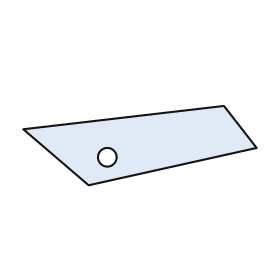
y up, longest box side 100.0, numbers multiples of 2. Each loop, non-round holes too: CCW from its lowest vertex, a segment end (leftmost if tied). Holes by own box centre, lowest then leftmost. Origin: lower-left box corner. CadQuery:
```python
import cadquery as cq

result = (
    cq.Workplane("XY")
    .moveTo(28.0, 0.0)
    .lineTo(100.0, 16.0)
    .lineTo(86.0, 34.0)
    .lineTo(0.0, 24.0)
    .close()
    .moveTo(36.0, 12.0)
    .circle(4.0)
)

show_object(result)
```